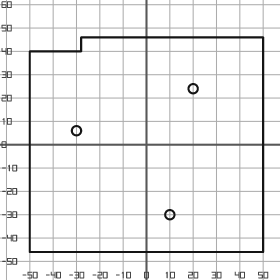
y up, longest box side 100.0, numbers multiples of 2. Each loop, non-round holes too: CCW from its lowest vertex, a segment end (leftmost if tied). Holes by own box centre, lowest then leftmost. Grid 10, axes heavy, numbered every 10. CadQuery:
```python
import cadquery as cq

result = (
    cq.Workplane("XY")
    .moveTo(-50.0, -46.0)
    .lineTo(50.0, -46.0)
    .lineTo(50.0, 46.0)
    .lineTo(-28.0, 46.0)
    .lineTo(-28.0, 40.0)
    .lineTo(-50.0, 40.0)
    .close()
    .moveTo(10.0, -30.0)
    .circle(2.0)
    .moveTo(-30.0, 6.0)
    .circle(2.0)
    .moveTo(20.0, 24.0)
    .circle(2.0)
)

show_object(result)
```